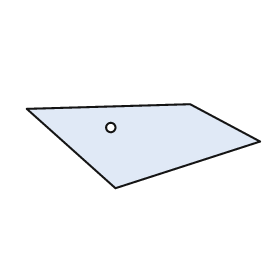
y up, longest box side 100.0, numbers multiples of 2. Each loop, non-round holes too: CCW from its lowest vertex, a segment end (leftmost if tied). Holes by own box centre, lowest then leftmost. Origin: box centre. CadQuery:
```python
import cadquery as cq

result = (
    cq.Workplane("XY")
    .moveTo(-12.0, -18.0)
    .lineTo(50.0, 2.0)
    .lineTo(20.0, 18.0)
    .lineTo(-50.0, 16.0)
    .close()
    .moveTo(-14.0, 8.0)
    .circle(2.0)
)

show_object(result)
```